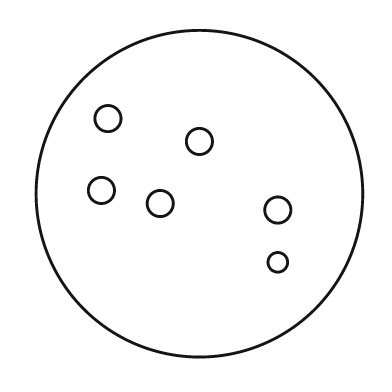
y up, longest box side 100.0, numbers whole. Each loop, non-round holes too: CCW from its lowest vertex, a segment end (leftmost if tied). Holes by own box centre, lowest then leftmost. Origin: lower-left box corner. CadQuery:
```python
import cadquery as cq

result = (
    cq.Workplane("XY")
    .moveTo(50.0, 50.0)
    .circle(50.0)
    .moveTo(74.0, 29.0)
    .circle(3.0)
    .moveTo(74.0, 45.0)
    .circle(4.0)
    .moveTo(38.0, 47.0)
    .circle(4.0)
    .moveTo(20.0, 51.0)
    .circle(4.0)
    .moveTo(50.0, 66.0)
    .circle(4.0)
    .moveTo(22.0, 73.0)
    .circle(4.0)
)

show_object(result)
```